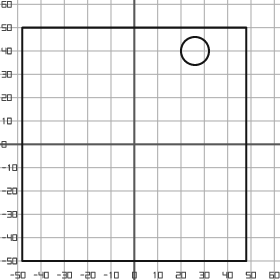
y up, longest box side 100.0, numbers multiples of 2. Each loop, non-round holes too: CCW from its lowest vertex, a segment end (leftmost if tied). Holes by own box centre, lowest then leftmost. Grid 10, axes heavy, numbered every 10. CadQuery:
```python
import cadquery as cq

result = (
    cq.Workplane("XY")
    .moveTo(-48.0, -50.0)
    .lineTo(48.0, -50.0)
    .lineTo(48.0, 50.0)
    .lineTo(-48.0, 50.0)
    .close()
    .moveTo(26.0, 40.0)
    .circle(6.0)
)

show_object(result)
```